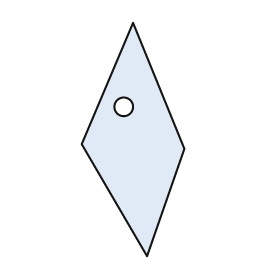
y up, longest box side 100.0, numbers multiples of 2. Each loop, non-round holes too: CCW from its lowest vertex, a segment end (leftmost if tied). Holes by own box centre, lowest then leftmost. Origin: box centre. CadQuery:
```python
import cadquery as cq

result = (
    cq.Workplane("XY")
    .moveTo(6.0, -50.0)
    .lineTo(22.0, -4.0)
    .lineTo(0.0, 50.0)
    .lineTo(-22.0, -2.0)
    .close()
    .moveTo(-4.0, 14.0)
    .circle(4.0)
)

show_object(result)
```